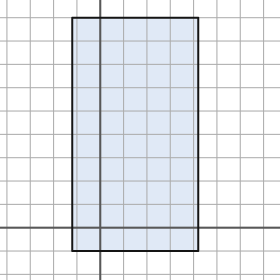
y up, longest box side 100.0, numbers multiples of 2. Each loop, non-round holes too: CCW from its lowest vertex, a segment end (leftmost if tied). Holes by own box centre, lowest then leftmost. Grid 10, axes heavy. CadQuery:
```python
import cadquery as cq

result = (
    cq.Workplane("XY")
    .moveTo(-12.0, -10.0)
    .lineTo(42.0, -10.0)
    .lineTo(42.0, 90.0)
    .lineTo(-12.0, 90.0)
    .close()
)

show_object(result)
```